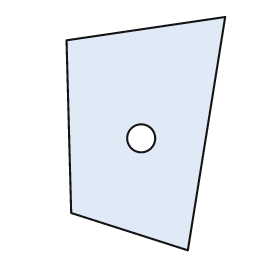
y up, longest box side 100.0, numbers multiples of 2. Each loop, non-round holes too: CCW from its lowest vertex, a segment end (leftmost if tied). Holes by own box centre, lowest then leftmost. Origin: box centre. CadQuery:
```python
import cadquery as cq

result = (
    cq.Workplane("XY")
    .moveTo(18.0, -50.0)
    .lineTo(34.0, 50.0)
    .lineTo(-34.0, 40.0)
    .lineTo(-32.0, -34.0)
    .close()
    .moveTo(-2.0, -2.0)
    .circle(6.0)
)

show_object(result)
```